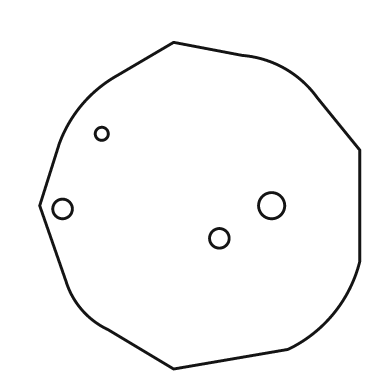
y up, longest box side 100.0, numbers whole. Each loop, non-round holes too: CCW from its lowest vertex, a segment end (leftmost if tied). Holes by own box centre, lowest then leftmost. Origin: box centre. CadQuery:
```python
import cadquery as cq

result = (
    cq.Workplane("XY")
    .moveTo(-8.0, -50.0)
    .lineTo(27.0, -44.0)
    .threePointArc((41.0, -33.0), (49.0, -17.0))
    .lineTo(49.0, 17.0)
    .lineTo(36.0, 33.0)
    .threePointArc((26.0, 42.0), (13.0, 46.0))
    .lineTo(-8.0, 50.0)
    .lineTo(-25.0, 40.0)
    .threePointArc((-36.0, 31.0), (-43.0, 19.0))
    .lineTo(-49.0, 0.0)
    .lineTo(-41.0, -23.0)
    .threePointArc((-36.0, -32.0), (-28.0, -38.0))
    .close()
    .moveTo(6.0, -10.0)
    .circle(3.0)
    .moveTo(-42.0, -1.0)
    .circle(3.0)
    .moveTo(22.0, 0.0)
    .circle(4.0)
    .moveTo(-30.0, 22.0)
    .circle(2.0)
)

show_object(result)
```